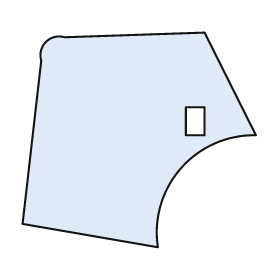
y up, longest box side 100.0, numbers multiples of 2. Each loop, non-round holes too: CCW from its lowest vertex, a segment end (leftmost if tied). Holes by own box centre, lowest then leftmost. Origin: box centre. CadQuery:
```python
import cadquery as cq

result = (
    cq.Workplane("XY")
    .moveTo(8.0, -46.0)
    .threePointArc((18.0, -12.0), (50.0, 2.0))
    .lineTo(28.0, 46.0)
    .lineTo(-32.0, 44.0)
    .threePointArc((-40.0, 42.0), (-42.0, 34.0))
    .lineTo(-50.0, -36.0)
    .close()
    .moveTo(20.0, 2.0)
    .lineTo(28.0, 2.0)
    .lineTo(28.0, 14.0)
    .lineTo(20.0, 14.0)
    .close()
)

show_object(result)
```